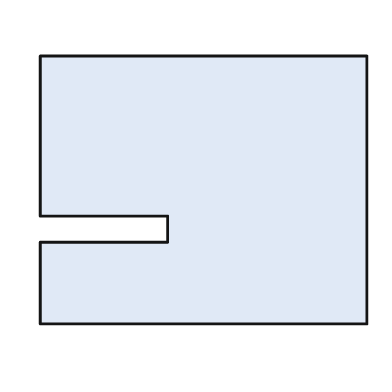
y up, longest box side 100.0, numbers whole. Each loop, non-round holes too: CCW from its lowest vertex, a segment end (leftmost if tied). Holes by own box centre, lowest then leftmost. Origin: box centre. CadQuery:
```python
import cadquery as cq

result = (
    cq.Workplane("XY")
    .moveTo(-50.0, -41.0)
    .lineTo(50.0, -41.0)
    .lineTo(50.0, 41.0)
    .lineTo(-50.0, 41.0)
    .lineTo(-50.0, -8.0)
    .lineTo(-11.0, -8.0)
    .lineTo(-11.0, -16.0)
    .lineTo(-50.0, -16.0)
    .close()
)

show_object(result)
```